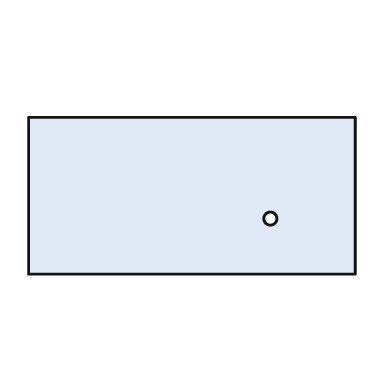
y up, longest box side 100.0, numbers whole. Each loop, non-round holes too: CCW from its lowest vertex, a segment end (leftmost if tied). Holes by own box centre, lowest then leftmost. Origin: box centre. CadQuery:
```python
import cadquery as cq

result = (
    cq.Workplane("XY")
    .moveTo(-50.0, -24.0)
    .lineTo(50.0, -24.0)
    .lineTo(50.0, 24.0)
    .lineTo(-50.0, 24.0)
    .close()
    .moveTo(24.0, -7.0)
    .circle(2.0)
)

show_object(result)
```